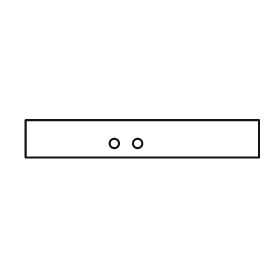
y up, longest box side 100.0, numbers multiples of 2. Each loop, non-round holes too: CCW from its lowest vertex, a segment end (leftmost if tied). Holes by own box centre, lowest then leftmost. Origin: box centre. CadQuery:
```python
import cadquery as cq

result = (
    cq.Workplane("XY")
    .moveTo(-50.0, -8.0)
    .lineTo(50.0, -8.0)
    .lineTo(50.0, 8.0)
    .lineTo(-50.0, 8.0)
    .close()
    .moveTo(-12.0, -2.0)
    .circle(2.0)
    .moveTo(-2.0, -2.0)
    .circle(2.0)
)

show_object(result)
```